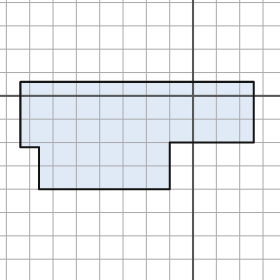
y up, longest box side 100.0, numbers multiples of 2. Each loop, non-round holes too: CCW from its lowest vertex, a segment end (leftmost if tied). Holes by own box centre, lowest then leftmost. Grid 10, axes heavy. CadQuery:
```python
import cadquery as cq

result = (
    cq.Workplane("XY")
    .moveTo(-66.0, -40.0)
    .lineTo(-10.0, -40.0)
    .lineTo(-10.0, -20.0)
    .lineTo(26.0, -20.0)
    .lineTo(26.0, 6.0)
    .lineTo(-74.0, 6.0)
    .lineTo(-74.0, -22.0)
    .lineTo(-66.0, -22.0)
    .close()
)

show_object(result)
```